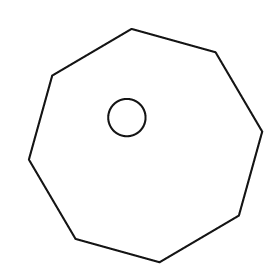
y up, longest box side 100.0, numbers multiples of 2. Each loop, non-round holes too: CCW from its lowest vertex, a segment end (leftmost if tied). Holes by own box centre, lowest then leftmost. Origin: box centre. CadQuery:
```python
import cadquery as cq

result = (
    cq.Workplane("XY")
    .moveTo(6.0, -50.0)
    .lineTo(40.0, -30.0)
    .lineTo(50.0, 6.0)
    .lineTo(30.0, 40.0)
    .lineTo(-6.0, 50.0)
    .lineTo(-40.0, 30.0)
    .lineTo(-50.0, -6.0)
    .lineTo(-30.0, -40.0)
    .close()
    .moveTo(-8.0, 12.0)
    .circle(8.0)
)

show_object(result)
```